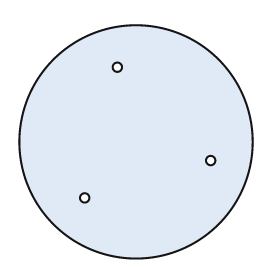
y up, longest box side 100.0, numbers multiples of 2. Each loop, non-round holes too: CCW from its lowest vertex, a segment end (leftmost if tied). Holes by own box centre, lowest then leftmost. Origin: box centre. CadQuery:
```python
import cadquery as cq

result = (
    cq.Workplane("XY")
    .moveTo(0.0, 0.0)
    .circle(50.0)
    .moveTo(-22.0, -24.0)
    .circle(2.0)
    .moveTo(32.0, -8.0)
    .circle(2.0)
    .moveTo(-8.0, 32.0)
    .circle(2.0)
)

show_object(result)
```